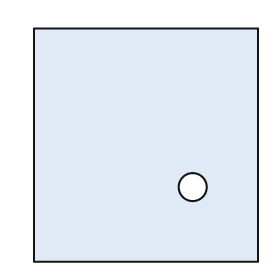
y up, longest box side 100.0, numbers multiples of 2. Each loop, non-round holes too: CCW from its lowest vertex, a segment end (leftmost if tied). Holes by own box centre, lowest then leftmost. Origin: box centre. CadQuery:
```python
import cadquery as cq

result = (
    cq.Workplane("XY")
    .moveTo(-48.0, -50.0)
    .lineTo(48.0, -50.0)
    .lineTo(48.0, 50.0)
    .lineTo(-48.0, 50.0)
    .close()
    .moveTo(20.0, -18.0)
    .circle(6.0)
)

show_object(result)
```